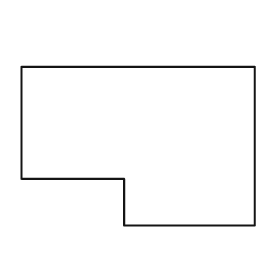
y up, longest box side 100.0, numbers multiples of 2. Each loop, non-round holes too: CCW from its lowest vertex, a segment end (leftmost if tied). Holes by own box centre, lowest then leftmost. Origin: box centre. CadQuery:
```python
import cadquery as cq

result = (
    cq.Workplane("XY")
    .moveTo(-6.0, -34.0)
    .lineTo(50.0, -34.0)
    .lineTo(50.0, 34.0)
    .lineTo(-50.0, 34.0)
    .lineTo(-50.0, -14.0)
    .lineTo(-6.0, -14.0)
    .close()
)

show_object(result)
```